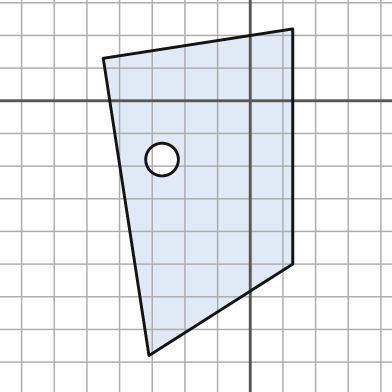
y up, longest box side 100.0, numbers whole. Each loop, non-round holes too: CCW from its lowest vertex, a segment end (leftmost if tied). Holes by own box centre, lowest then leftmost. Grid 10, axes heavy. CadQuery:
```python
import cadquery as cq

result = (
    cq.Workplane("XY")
    .moveTo(-31.0, -78.0)
    .lineTo(13.0, -50.0)
    .lineTo(13.0, 22.0)
    .lineTo(-45.0, 13.0)
    .close()
    .moveTo(-27.0, -18.0)
    .circle(5.0)
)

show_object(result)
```